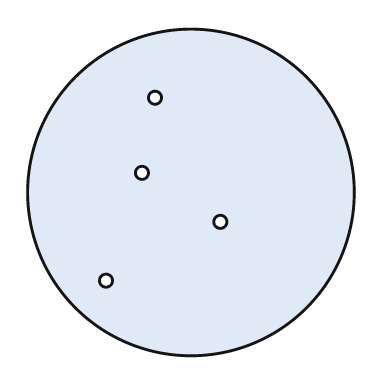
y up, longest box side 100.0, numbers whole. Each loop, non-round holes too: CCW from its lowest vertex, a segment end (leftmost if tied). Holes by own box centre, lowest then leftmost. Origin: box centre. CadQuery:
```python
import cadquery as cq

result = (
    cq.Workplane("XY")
    .moveTo(0.0, 0.0)
    .circle(50.0)
    .moveTo(-26.0, -27.0)
    .circle(2.0)
    .moveTo(9.0, -9.0)
    .circle(2.0)
    .moveTo(-15.0, 6.0)
    .circle(2.0)
    .moveTo(-11.0, 29.0)
    .circle(2.0)
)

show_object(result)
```